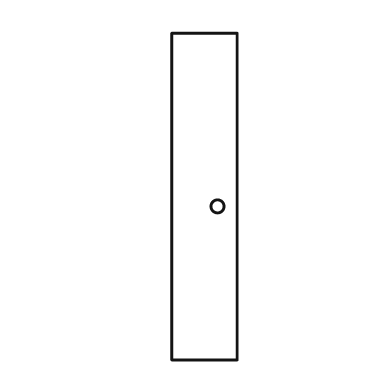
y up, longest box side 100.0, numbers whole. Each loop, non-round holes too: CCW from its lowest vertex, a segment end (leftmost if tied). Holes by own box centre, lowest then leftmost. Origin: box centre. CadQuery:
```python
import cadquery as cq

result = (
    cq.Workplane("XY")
    .moveTo(-10.0, -50.0)
    .lineTo(10.0, -50.0)
    .lineTo(10.0, 50.0)
    .lineTo(-10.0, 50.0)
    .close()
    .moveTo(4.0, -3.0)
    .circle(2.0)
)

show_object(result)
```